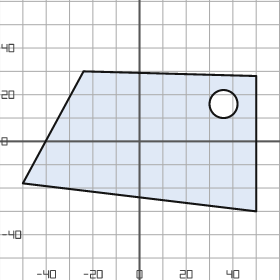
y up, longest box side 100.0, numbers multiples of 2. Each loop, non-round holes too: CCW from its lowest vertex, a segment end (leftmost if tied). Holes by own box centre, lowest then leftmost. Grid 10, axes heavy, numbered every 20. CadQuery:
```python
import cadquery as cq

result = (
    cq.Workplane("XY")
    .moveTo(50.0, -30.0)
    .lineTo(50.0, 28.0)
    .lineTo(-24.0, 30.0)
    .lineTo(-50.0, -18.0)
    .close()
    .moveTo(36.0, 16.0)
    .circle(6.0)
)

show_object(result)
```